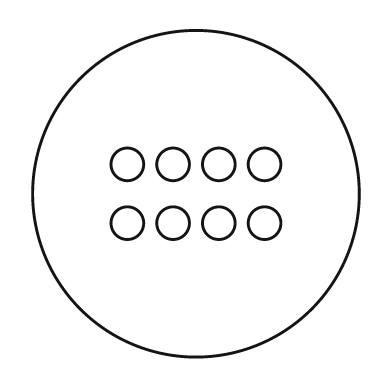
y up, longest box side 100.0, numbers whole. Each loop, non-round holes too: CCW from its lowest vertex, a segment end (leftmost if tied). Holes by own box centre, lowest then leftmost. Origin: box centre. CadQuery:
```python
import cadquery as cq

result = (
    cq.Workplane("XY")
    .moveTo(0.0, 0.0)
    .circle(50.0)
    .moveTo(-21.0, -9.0)
    .circle(5.0)
    .moveTo(-7.0, -9.0)
    .circle(5.0)
    .moveTo(7.0, -9.0)
    .circle(5.0)
    .moveTo(21.0, -9.0)
    .circle(5.0)
    .moveTo(-21.0, 9.0)
    .circle(5.0)
    .moveTo(-7.0, 9.0)
    .circle(5.0)
    .moveTo(7.0, 9.0)
    .circle(5.0)
    .moveTo(21.0, 9.0)
    .circle(5.0)
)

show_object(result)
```